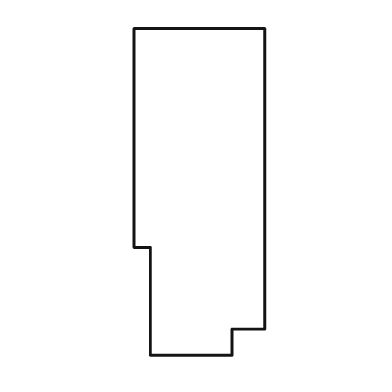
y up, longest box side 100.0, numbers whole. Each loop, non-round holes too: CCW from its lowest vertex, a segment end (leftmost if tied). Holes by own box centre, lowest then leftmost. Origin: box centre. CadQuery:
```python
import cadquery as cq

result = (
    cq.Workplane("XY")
    .moveTo(-15.0, -50.0)
    .lineTo(10.0, -50.0)
    .lineTo(10.0, -42.0)
    .lineTo(20.0, -42.0)
    .lineTo(20.0, 50.0)
    .lineTo(-20.0, 50.0)
    .lineTo(-20.0, -17.0)
    .lineTo(-15.0, -17.0)
    .close()
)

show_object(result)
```